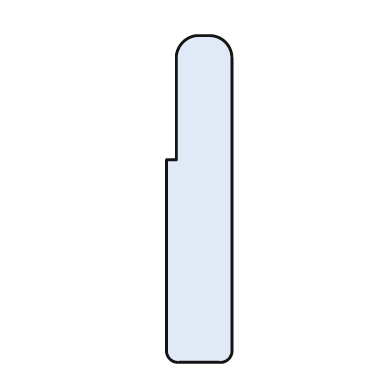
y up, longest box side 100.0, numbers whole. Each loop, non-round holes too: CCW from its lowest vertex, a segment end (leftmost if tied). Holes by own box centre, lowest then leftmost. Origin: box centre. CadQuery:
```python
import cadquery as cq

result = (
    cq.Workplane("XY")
    .moveTo(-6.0, -50.0)
    .lineTo(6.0, -50.0)
    .threePointArc((9.0, -49.0), (10.0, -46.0))
    .lineTo(10.0, 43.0)
    .threePointArc((8.0, 48.0), (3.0, 50.0))
    .lineTo(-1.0, 50.0)
    .threePointArc((-5.0, 48.0), (-7.0, 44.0))
    .lineTo(-7.0, 12.0)
    .lineTo(-10.0, 12.0)
    .lineTo(-10.0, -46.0)
    .threePointArc((-9.0, -49.0), (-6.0, -50.0))
    .close()
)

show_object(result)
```